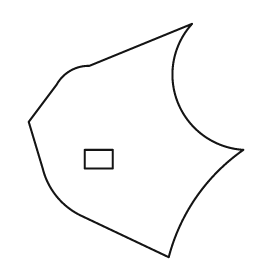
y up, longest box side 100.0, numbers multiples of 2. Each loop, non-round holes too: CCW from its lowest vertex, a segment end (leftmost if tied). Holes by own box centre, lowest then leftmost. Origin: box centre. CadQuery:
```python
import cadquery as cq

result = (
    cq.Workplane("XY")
    .moveTo(14.0, -50.0)
    .threePointArc((26.0, -24.0), (46.0, -4.0))
    .threePointArc((18.0, 16.0), (24.0, 50.0))
    .lineTo(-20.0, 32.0)
    .threePointArc((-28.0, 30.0), (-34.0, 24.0))
    .lineTo(-46.0, 8.0)
    .lineTo(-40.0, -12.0)
    .threePointArc((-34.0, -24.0), (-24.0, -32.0))
    .close()
    .moveTo(-22.0, -12.0)
    .lineTo(-10.0, -12.0)
    .lineTo(-10.0, -4.0)
    .lineTo(-22.0, -4.0)
    .close()
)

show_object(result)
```